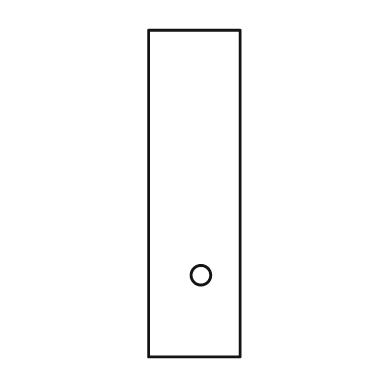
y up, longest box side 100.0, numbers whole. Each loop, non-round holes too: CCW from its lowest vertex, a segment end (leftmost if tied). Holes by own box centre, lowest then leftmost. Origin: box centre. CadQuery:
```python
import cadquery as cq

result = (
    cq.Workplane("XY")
    .moveTo(-14.0, -50.0)
    .lineTo(14.0, -50.0)
    .lineTo(14.0, 50.0)
    .lineTo(-14.0, 50.0)
    .close()
    .moveTo(2.0, -25.0)
    .circle(3.0)
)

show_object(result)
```